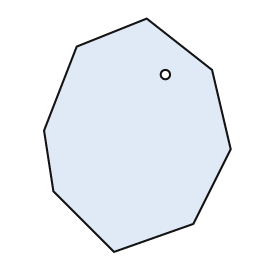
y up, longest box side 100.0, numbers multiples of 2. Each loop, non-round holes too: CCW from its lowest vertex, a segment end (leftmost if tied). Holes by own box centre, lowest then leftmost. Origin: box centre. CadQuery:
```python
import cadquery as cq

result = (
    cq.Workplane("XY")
    .moveTo(-10.0, -50.0)
    .lineTo(24.0, -38.0)
    .lineTo(40.0, -6.0)
    .lineTo(32.0, 28.0)
    .lineTo(4.0, 50.0)
    .lineTo(-26.0, 38.0)
    .lineTo(-40.0, 2.0)
    .lineTo(-36.0, -24.0)
    .close()
    .moveTo(12.0, 26.0)
    .circle(2.0)
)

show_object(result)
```